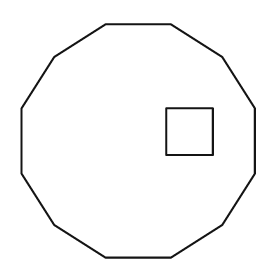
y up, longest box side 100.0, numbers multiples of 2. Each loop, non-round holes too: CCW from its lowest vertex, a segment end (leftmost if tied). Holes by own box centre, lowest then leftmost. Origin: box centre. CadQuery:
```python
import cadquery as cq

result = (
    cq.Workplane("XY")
    .moveTo(-14.0, -50.0)
    .lineTo(14.0, -50.0)
    .lineTo(36.0, -36.0)
    .lineTo(50.0, -14.0)
    .lineTo(50.0, 14.0)
    .lineTo(36.0, 36.0)
    .lineTo(14.0, 50.0)
    .lineTo(-14.0, 50.0)
    .lineTo(-36.0, 36.0)
    .lineTo(-50.0, 14.0)
    .lineTo(-50.0, -14.0)
    .lineTo(-36.0, -36.0)
    .close()
    .moveTo(12.0, -6.0)
    .lineTo(32.0, -6.0)
    .lineTo(32.0, 14.0)
    .lineTo(12.0, 14.0)
    .close()
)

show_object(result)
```